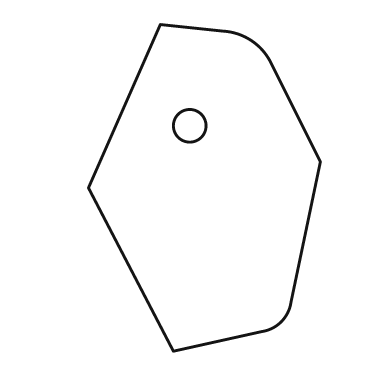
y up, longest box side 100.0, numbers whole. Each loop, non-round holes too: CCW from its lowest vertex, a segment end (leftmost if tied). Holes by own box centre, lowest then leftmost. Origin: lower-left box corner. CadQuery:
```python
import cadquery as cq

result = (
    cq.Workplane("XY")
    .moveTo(26.0, 0.0)
    .lineTo(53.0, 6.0)
    .threePointArc((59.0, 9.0), (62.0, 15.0))
    .lineTo(71.0, 58.0)
    .lineTo(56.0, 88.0)
    .threePointArc((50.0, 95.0), (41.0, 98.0))
    .lineTo(22.0, 100.0)
    .lineTo(0.0, 50.0)
    .close()
    .moveTo(31.0, 69.0)
    .circle(5.0)
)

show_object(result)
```